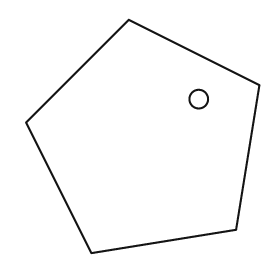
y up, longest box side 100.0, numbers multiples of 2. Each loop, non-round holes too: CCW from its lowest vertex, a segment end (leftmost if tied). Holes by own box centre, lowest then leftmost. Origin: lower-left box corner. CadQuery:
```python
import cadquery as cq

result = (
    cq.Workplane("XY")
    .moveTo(28.0, 0.0)
    .lineTo(90.0, 10.0)
    .lineTo(100.0, 72.0)
    .lineTo(44.0, 100.0)
    .lineTo(0.0, 56.0)
    .close()
    .moveTo(74.0, 66.0)
    .circle(4.0)
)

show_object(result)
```